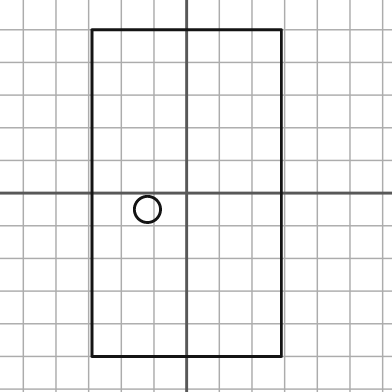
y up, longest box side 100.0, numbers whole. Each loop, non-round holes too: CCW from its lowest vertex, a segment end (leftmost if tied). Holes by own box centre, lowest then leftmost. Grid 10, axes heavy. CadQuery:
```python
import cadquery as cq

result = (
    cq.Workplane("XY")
    .moveTo(-29.0, -50.0)
    .lineTo(29.0, -50.0)
    .lineTo(29.0, 50.0)
    .lineTo(-29.0, 50.0)
    .close()
    .moveTo(-12.0, -5.0)
    .circle(4.0)
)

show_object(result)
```